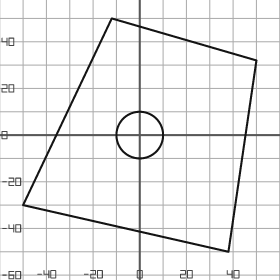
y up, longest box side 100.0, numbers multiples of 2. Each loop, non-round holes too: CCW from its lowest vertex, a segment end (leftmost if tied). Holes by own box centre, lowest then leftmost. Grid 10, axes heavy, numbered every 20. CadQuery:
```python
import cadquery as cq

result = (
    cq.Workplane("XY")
    .moveTo(38.0, -50.0)
    .lineTo(50.0, 32.0)
    .lineTo(-12.0, 50.0)
    .lineTo(-50.0, -30.0)
    .close()
    .moveTo(0.0, 0.0)
    .circle(10.0)
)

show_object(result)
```